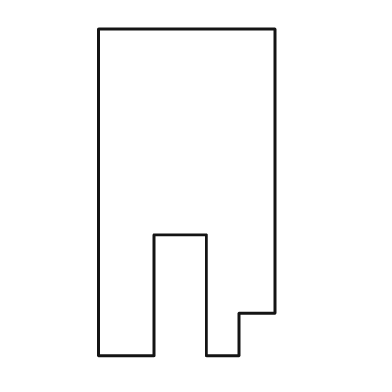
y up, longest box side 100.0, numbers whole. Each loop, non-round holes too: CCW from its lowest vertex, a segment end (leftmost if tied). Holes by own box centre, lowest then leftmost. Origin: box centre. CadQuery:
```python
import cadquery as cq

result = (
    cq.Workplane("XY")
    .moveTo(-27.0, -50.0)
    .lineTo(-10.0, -50.0)
    .lineTo(-10.0, -13.0)
    .lineTo(6.0, -13.0)
    .lineTo(6.0, -50.0)
    .lineTo(16.0, -50.0)
    .lineTo(16.0, -37.0)
    .lineTo(27.0, -37.0)
    .lineTo(27.0, 50.0)
    .lineTo(-27.0, 50.0)
    .close()
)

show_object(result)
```